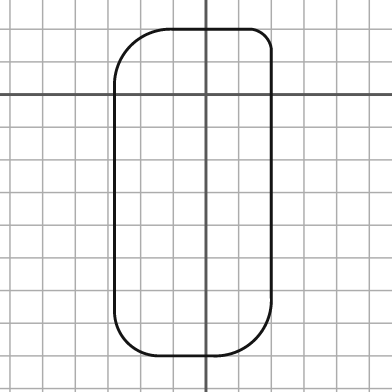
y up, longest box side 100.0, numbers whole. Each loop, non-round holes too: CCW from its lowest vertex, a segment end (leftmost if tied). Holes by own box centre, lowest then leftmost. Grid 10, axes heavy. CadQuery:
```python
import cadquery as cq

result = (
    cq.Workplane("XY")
    .moveTo(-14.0, -80.0)
    .lineTo(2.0, -80.0)
    .threePointArc((15.0, -75.0), (20.0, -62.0))
    .lineTo(20.0, 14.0)
    .threePointArc((18.0, 18.0), (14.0, 20.0))
    .lineTo(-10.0, 20.0)
    .threePointArc((-23.0, 15.0), (-28.0, 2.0))
    .lineTo(-28.0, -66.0)
    .threePointArc((-24.0, -76.0), (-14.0, -80.0))
    .close()
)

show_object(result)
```